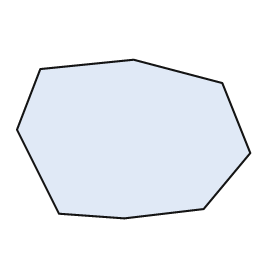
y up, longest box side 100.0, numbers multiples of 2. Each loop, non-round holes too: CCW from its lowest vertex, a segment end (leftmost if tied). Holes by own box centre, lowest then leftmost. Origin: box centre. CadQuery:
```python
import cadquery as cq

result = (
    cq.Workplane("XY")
    .moveTo(-4.0, -34.0)
    .lineTo(30.0, -30.0)
    .lineTo(50.0, -6.0)
    .lineTo(38.0, 24.0)
    .lineTo(0.0, 34.0)
    .lineTo(-40.0, 30.0)
    .lineTo(-50.0, 4.0)
    .lineTo(-32.0, -32.0)
    .close()
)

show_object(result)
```